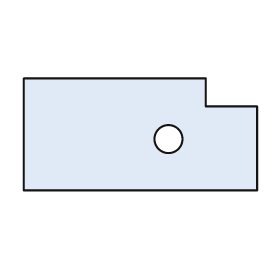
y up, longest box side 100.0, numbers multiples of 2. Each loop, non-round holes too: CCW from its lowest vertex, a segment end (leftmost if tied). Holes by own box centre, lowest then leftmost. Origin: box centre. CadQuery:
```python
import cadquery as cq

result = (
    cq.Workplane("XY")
    .moveTo(-50.0, -24.0)
    .lineTo(50.0, -24.0)
    .lineTo(50.0, 12.0)
    .lineTo(28.0, 12.0)
    .lineTo(28.0, 24.0)
    .lineTo(-50.0, 24.0)
    .close()
    .moveTo(12.0, -2.0)
    .circle(6.0)
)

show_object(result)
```